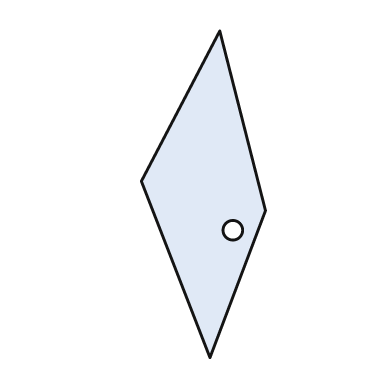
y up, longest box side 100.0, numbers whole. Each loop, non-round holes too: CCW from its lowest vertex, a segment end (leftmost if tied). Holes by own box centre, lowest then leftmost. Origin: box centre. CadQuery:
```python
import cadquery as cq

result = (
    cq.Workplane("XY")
    .moveTo(2.0, -50.0)
    .lineTo(19.0, -5.0)
    .lineTo(5.0, 50.0)
    .lineTo(-19.0, 4.0)
    .close()
    .moveTo(9.0, -11.0)
    .circle(3.0)
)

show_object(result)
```